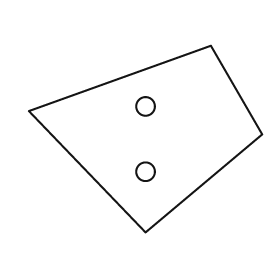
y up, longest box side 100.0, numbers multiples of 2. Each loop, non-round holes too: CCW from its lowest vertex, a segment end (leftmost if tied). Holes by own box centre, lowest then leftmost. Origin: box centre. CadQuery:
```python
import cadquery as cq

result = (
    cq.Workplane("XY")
    .moveTo(0.0, -40.0)
    .lineTo(50.0, 2.0)
    .lineTo(28.0, 40.0)
    .lineTo(-50.0, 12.0)
    .close()
    .moveTo(0.0, -14.0)
    .circle(4.0)
    .moveTo(0.0, 14.0)
    .circle(4.0)
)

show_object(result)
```